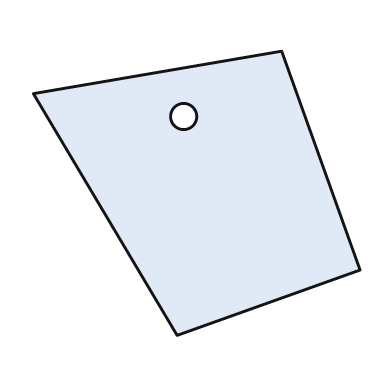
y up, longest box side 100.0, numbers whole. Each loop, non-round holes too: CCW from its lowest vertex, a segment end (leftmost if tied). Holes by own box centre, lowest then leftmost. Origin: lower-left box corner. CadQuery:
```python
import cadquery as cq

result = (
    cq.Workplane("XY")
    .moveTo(44.0, 0.0)
    .lineTo(100.0, 20.0)
    .lineTo(76.0, 87.0)
    .lineTo(0.0, 74.0)
    .close()
    .moveTo(46.0, 67.0)
    .circle(4.0)
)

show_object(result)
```